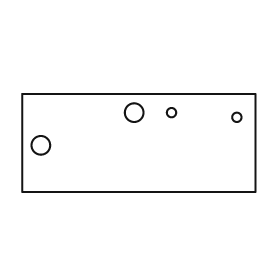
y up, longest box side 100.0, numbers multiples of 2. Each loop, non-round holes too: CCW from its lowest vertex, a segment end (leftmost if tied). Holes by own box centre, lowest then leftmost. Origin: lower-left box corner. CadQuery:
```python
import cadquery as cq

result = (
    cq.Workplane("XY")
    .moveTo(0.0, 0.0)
    .lineTo(100.0, 0.0)
    .lineTo(100.0, 42.0)
    .lineTo(0.0, 42.0)
    .close()
    .moveTo(8.0, 20.0)
    .circle(4.0)
    .moveTo(92.0, 32.0)
    .circle(2.0)
    .moveTo(48.0, 34.0)
    .circle(4.0)
    .moveTo(64.0, 34.0)
    .circle(2.0)
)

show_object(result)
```